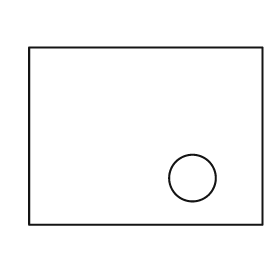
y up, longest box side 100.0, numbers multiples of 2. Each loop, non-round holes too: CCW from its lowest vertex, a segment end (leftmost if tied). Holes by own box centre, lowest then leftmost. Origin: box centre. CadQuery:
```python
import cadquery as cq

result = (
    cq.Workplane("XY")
    .moveTo(-50.0, -38.0)
    .lineTo(50.0, -38.0)
    .lineTo(50.0, 38.0)
    .lineTo(-50.0, 38.0)
    .close()
    .moveTo(20.0, -18.0)
    .circle(10.0)
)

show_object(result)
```